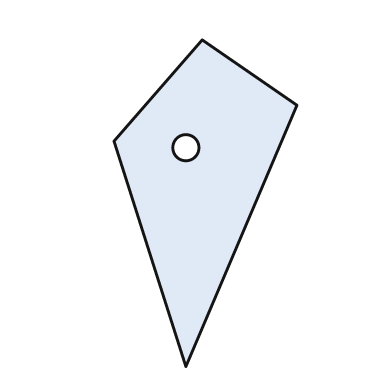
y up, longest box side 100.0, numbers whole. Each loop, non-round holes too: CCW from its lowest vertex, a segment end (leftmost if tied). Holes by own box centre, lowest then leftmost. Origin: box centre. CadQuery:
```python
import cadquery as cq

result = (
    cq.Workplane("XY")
    .moveTo(-6.0, -50.0)
    .lineTo(28.0, 30.0)
    .lineTo(-1.0, 50.0)
    .lineTo(-28.0, 19.0)
    .close()
    .moveTo(-6.0, 17.0)
    .circle(4.0)
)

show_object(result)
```